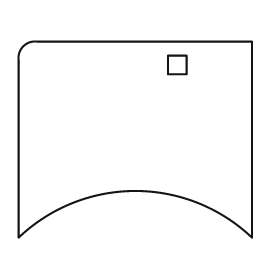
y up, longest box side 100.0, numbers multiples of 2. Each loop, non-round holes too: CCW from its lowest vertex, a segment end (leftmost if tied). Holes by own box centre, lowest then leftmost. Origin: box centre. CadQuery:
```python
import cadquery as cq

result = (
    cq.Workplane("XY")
    .moveTo(-50.0, -42.0)
    .threePointArc((0.0, -22.0), (50.0, -42.0))
    .lineTo(50.0, 42.0)
    .lineTo(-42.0, 42.0)
    .threePointArc((-48.0, 40.0), (-50.0, 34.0))
    .close()
    .moveTo(14.0, 28.0)
    .lineTo(22.0, 28.0)
    .lineTo(22.0, 36.0)
    .lineTo(14.0, 36.0)
    .close()
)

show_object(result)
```